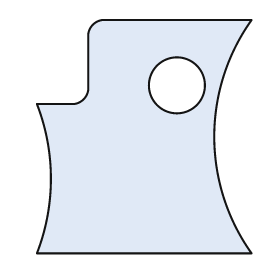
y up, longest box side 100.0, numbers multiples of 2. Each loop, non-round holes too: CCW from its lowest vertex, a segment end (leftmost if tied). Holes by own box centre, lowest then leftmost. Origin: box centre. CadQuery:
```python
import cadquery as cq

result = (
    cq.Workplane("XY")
    .moveTo(-46.0, -50.0)
    .lineTo(46.0, -50.0)
    .threePointArc((30.0, 0.0), (46.0, 50.0))
    .lineTo(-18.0, 50.0)
    .threePointArc((-22.0, 48.0), (-24.0, 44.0))
    .lineTo(-24.0, 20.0)
    .threePointArc((-26.0, 16.0), (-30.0, 14.0))
    .lineTo(-46.0, 14.0)
    .threePointArc((-40.0, -18.0), (-46.0, -50.0))
    .close()
    .moveTo(14.0, 22.0)
    .circle(12.0)
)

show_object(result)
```